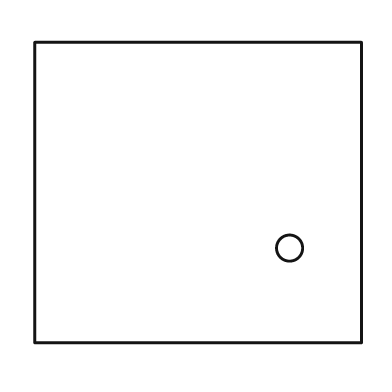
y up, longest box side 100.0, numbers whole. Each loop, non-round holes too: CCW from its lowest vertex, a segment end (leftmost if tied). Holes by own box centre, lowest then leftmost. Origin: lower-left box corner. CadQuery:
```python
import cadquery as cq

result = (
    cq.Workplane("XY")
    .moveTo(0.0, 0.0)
    .lineTo(100.0, 0.0)
    .lineTo(100.0, 92.0)
    .lineTo(0.0, 92.0)
    .close()
    .moveTo(78.0, 29.0)
    .circle(4.0)
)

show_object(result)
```